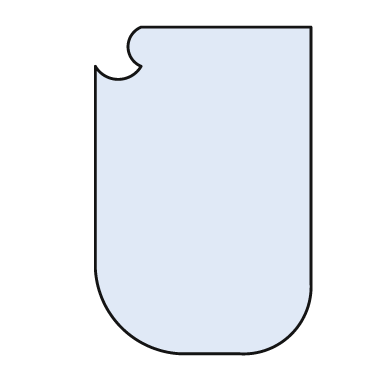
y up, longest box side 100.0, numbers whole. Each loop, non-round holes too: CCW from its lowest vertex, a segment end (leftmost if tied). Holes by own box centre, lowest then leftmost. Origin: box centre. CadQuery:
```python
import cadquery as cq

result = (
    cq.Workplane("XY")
    .moveTo(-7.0, -50.0)
    .lineTo(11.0, -50.0)
    .threePointArc((27.0, -44.0), (33.0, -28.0))
    .lineTo(33.0, 50.0)
    .lineTo(-19.0, 50.0)
    .threePointArc((-23.0, 44.0), (-19.0, 38.0))
    .threePointArc((-26.0, 34.0), (-33.0, 38.0))
    .lineTo(-33.0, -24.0)
    .threePointArc((-25.0, -42.0), (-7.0, -50.0))
    .close()
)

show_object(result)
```